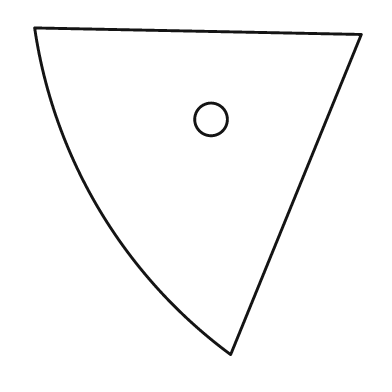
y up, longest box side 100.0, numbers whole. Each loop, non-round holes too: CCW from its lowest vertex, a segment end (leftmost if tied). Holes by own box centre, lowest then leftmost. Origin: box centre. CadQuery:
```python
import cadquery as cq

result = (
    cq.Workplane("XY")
    .moveTo(10.0, -50.0)
    .lineTo(50.0, 48.0)
    .lineTo(-50.0, 50.0)
    .threePointArc((-30.0, -6.0), (10.0, -50.0))
    .close()
    .moveTo(4.0, 22.0)
    .circle(5.0)
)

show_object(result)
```